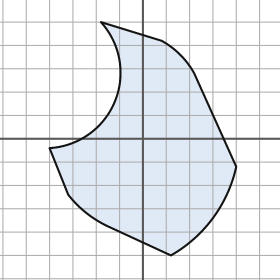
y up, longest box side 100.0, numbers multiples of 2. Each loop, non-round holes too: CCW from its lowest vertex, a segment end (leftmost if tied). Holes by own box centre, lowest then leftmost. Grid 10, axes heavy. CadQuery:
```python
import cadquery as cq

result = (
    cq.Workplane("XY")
    .moveTo(12.0, -50.0)
    .threePointArc((30.0, -34.0), (40.0, -12.0))
    .lineTo(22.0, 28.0)
    .threePointArc((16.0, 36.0), (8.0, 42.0))
    .lineTo(-18.0, 50.0)
    .threePointArc((-12.0, 16.0), (-40.0, -4.0))
    .lineTo(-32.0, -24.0)
    .threePointArc((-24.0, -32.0), (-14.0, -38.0))
    .close()
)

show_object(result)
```